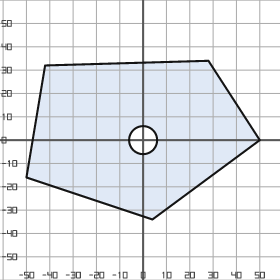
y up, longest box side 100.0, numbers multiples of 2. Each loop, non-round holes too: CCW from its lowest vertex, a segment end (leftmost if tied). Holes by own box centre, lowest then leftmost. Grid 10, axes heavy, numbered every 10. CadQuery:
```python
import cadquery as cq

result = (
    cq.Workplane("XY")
    .moveTo(4.0, -34.0)
    .lineTo(50.0, 0.0)
    .lineTo(28.0, 34.0)
    .lineTo(-42.0, 32.0)
    .lineTo(-50.0, -16.0)
    .close()
    .moveTo(0.0, 0.0)
    .circle(6.0)
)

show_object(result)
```